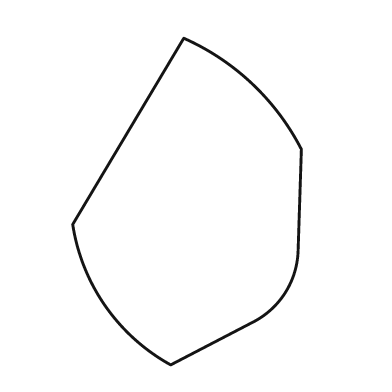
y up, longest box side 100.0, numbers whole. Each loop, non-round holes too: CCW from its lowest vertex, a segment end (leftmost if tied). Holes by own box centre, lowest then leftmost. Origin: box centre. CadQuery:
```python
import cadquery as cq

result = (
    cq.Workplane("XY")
    .moveTo(-5.0, -50.0)
    .lineTo(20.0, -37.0)
    .threePointArc((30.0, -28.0), (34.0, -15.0))
    .lineTo(35.0, 16.0)
    .threePointArc((20.0, 36.0), (-1.0, 50.0))
    .lineTo(-35.0, -7.0)
    .threePointArc((-25.0, -32.0), (-5.0, -50.0))
    .close()
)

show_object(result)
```